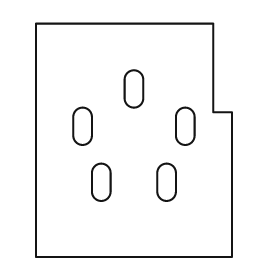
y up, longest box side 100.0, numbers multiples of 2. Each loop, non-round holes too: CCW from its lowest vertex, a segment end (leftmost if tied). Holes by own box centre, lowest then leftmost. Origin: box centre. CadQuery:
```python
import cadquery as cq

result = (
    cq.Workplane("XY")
    .moveTo(-42.0, -50.0)
    .lineTo(42.0, -50.0)
    .lineTo(42.0, 12.0)
    .lineTo(34.0, 12.0)
    .lineTo(34.0, 50.0)
    .lineTo(-42.0, 50.0)
    .close()
    .moveTo(-18.0, -22.0)
    .threePointArc((-14.0, -26.0), (-10.0, -22.0))
    .lineTo(-10.0, -14.0)
    .threePointArc((-14.0, -10.0), (-18.0, -14.0))
    .close()
    .moveTo(10.0, -22.0)
    .threePointArc((14.0, -26.0), (18.0, -22.0))
    .lineTo(18.0, -14.0)
    .threePointArc((14.0, -10.0), (10.0, -14.0))
    .close()
    .moveTo(-26.0, 2.0)
    .threePointArc((-22.0, -2.0), (-18.0, 2.0))
    .lineTo(-18.0, 10.0)
    .threePointArc((-22.0, 14.0), (-26.0, 10.0))
    .close()
    .moveTo(18.0, 2.0)
    .threePointArc((22.0, -2.0), (26.0, 2.0))
    .lineTo(26.0, 10.0)
    .threePointArc((22.0, 14.0), (18.0, 10.0))
    .close()
    .moveTo(-4.0, 18.0)
    .threePointArc((0.0, 14.0), (4.0, 18.0))
    .lineTo(4.0, 26.0)
    .threePointArc((0.0, 30.0), (-4.0, 26.0))
    .close()
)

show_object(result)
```